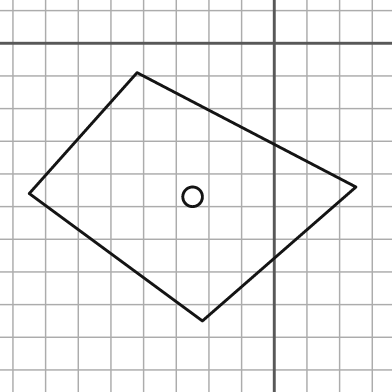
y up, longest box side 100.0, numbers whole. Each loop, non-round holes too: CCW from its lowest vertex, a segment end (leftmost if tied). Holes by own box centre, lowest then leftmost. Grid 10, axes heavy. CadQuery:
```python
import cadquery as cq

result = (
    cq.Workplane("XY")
    .moveTo(-22.0, -85.0)
    .lineTo(25.0, -44.0)
    .lineTo(-42.0, -9.0)
    .lineTo(-75.0, -46.0)
    .close()
    .moveTo(-25.0, -47.0)
    .circle(3.0)
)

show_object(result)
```